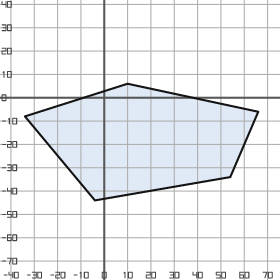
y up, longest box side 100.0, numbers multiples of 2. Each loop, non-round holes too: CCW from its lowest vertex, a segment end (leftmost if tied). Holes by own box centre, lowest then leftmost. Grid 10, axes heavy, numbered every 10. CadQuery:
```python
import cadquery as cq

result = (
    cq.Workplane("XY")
    .moveTo(-4.0, -44.0)
    .lineTo(54.0, -34.0)
    .lineTo(66.0, -6.0)
    .lineTo(10.0, 6.0)
    .lineTo(-34.0, -8.0)
    .close()
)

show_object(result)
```